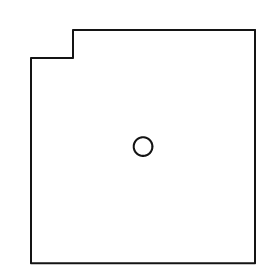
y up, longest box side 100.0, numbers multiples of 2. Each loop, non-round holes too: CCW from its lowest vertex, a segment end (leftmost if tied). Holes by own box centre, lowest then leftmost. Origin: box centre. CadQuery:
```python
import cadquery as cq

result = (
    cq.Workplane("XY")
    .moveTo(-48.0, -50.0)
    .lineTo(48.0, -50.0)
    .lineTo(48.0, 50.0)
    .lineTo(-30.0, 50.0)
    .lineTo(-30.0, 38.0)
    .lineTo(-48.0, 38.0)
    .close()
    .moveTo(0.0, 0.0)
    .circle(4.0)
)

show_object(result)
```